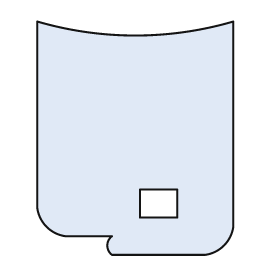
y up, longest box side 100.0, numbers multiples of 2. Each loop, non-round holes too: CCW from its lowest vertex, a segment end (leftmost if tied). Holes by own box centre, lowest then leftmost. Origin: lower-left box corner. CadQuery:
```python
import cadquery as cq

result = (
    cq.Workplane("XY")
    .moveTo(32.0, 0.0)
    .lineTo(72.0, 0.0)
    .threePointArc((80.0, 4.0), (84.0, 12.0))
    .lineTo(84.0, 100.0)
    .threePointArc((42.0, 94.0), (0.0, 100.0))
    .lineTo(0.0, 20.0)
    .threePointArc((4.0, 12.0), (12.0, 8.0))
    .lineTo(32.0, 8.0)
    .threePointArc((30.0, 4.0), (32.0, 0.0))
    .close()
    .moveTo(44.0, 16.0)
    .lineTo(60.0, 16.0)
    .lineTo(60.0, 28.0)
    .lineTo(44.0, 28.0)
    .close()
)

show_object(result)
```